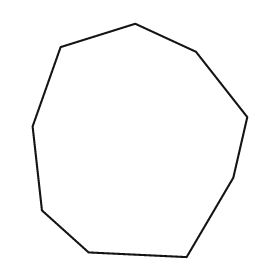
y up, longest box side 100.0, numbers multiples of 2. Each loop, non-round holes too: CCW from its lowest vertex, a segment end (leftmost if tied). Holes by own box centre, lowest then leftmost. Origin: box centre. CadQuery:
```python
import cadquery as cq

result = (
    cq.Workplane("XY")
    .moveTo(20.0, -50.0)
    .lineTo(40.0, -16.0)
    .lineTo(46.0, 10.0)
    .lineTo(24.0, 38.0)
    .lineTo(-2.0, 50.0)
    .lineTo(-34.0, 40.0)
    .lineTo(-46.0, 6.0)
    .lineTo(-42.0, -30.0)
    .lineTo(-22.0, -48.0)
    .close()
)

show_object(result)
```